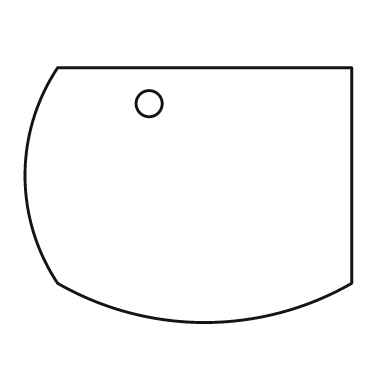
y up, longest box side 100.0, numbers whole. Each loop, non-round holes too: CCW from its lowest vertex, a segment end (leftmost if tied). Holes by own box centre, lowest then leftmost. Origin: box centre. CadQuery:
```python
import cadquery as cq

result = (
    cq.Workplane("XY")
    .moveTo(-40.0, -27.0)
    .threePointArc((5.0, -39.0), (50.0, -27.0))
    .lineTo(50.0, 39.0)
    .lineTo(-40.0, 39.0)
    .threePointArc((-50.0, 6.0), (-40.0, -27.0))
    .close()
    .moveTo(-12.0, 28.0)
    .circle(4.0)
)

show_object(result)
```